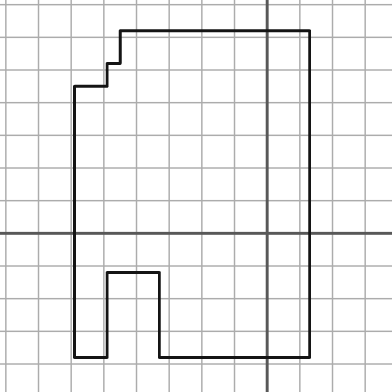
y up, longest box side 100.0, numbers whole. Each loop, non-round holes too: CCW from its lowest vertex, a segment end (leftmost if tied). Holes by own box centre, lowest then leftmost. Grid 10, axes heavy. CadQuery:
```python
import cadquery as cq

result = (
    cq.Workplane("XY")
    .moveTo(-59.0, -38.0)
    .lineTo(-49.0, -38.0)
    .lineTo(-49.0, -12.0)
    .lineTo(-33.0, -12.0)
    .lineTo(-33.0, -38.0)
    .lineTo(13.0, -38.0)
    .lineTo(13.0, 62.0)
    .lineTo(-45.0, 62.0)
    .lineTo(-45.0, 52.0)
    .lineTo(-49.0, 52.0)
    .lineTo(-49.0, 45.0)
    .lineTo(-59.0, 45.0)
    .close()
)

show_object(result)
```